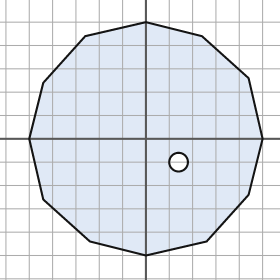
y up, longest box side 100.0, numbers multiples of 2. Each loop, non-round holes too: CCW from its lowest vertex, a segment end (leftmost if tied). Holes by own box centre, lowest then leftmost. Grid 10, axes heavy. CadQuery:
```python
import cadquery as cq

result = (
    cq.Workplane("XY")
    .moveTo(0.0, -50.0)
    .lineTo(26.0, -44.0)
    .lineTo(44.0, -24.0)
    .lineTo(50.0, 0.0)
    .lineTo(44.0, 26.0)
    .lineTo(24.0, 44.0)
    .lineTo(0.0, 50.0)
    .lineTo(-26.0, 44.0)
    .lineTo(-44.0, 24.0)
    .lineTo(-50.0, 0.0)
    .lineTo(-44.0, -26.0)
    .lineTo(-24.0, -44.0)
    .close()
    .moveTo(14.0, -10.0)
    .circle(4.0)
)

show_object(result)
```